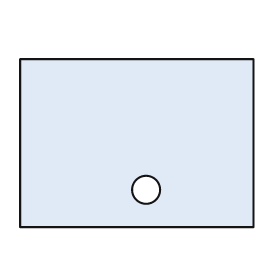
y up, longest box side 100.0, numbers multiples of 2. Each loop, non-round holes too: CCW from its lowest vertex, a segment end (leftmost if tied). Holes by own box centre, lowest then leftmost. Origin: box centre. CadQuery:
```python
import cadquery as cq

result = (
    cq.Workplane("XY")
    .moveTo(-50.0, -36.0)
    .lineTo(50.0, -36.0)
    .lineTo(50.0, 36.0)
    .lineTo(-50.0, 36.0)
    .close()
    .moveTo(4.0, -20.0)
    .circle(6.0)
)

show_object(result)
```